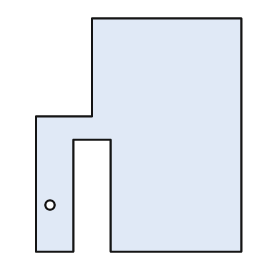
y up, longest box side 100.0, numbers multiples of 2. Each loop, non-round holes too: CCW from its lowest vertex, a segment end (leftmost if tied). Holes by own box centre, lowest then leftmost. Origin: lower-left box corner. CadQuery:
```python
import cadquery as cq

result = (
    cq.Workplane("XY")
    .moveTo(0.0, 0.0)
    .lineTo(16.0, 0.0)
    .lineTo(16.0, 48.0)
    .lineTo(32.0, 48.0)
    .lineTo(32.0, 0.0)
    .lineTo(88.0, 0.0)
    .lineTo(88.0, 100.0)
    .lineTo(24.0, 100.0)
    .lineTo(24.0, 58.0)
    .lineTo(0.0, 58.0)
    .close()
    .moveTo(6.0, 20.0)
    .circle(2.0)
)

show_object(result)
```